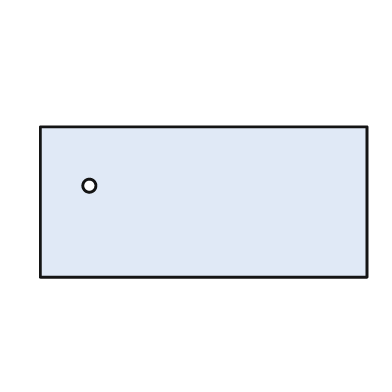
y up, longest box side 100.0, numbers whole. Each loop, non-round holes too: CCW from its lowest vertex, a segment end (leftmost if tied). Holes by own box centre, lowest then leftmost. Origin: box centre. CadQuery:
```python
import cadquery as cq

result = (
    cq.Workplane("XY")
    .moveTo(-50.0, -23.0)
    .lineTo(50.0, -23.0)
    .lineTo(50.0, 23.0)
    .lineTo(-50.0, 23.0)
    .close()
    .moveTo(-35.0, 5.0)
    .circle(2.0)
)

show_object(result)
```